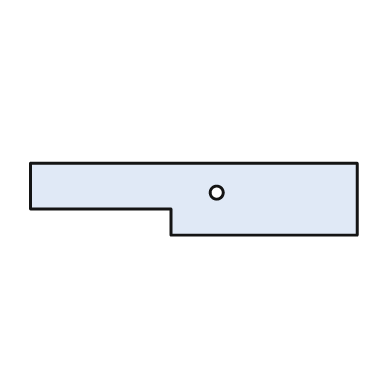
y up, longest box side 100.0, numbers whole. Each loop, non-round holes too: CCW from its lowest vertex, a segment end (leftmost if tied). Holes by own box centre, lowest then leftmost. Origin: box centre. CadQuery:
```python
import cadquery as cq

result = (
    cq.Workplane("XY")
    .moveTo(-7.0, -11.0)
    .lineTo(50.0, -11.0)
    .lineTo(50.0, 11.0)
    .lineTo(-50.0, 11.0)
    .lineTo(-50.0, -3.0)
    .lineTo(-7.0, -3.0)
    .close()
    .moveTo(7.0, 2.0)
    .circle(2.0)
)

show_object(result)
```